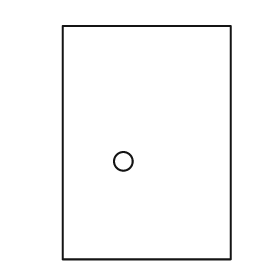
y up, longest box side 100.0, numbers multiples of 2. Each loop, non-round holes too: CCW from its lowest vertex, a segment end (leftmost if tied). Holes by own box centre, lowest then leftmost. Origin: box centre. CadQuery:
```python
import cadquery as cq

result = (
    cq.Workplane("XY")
    .moveTo(-36.0, -50.0)
    .lineTo(36.0, -50.0)
    .lineTo(36.0, 50.0)
    .lineTo(-36.0, 50.0)
    .close()
    .moveTo(-10.0, -8.0)
    .circle(4.0)
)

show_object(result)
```